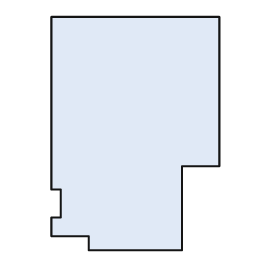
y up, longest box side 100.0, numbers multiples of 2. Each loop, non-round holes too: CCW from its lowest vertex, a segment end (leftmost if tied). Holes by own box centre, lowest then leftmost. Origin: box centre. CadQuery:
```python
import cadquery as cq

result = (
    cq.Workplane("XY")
    .moveTo(-20.0, -50.0)
    .lineTo(20.0, -50.0)
    .lineTo(20.0, -14.0)
    .lineTo(36.0, -14.0)
    .lineTo(36.0, 50.0)
    .lineTo(-36.0, 50.0)
    .lineTo(-36.0, -24.0)
    .lineTo(-32.0, -24.0)
    .lineTo(-32.0, -36.0)
    .lineTo(-36.0, -36.0)
    .lineTo(-36.0, -44.0)
    .lineTo(-20.0, -44.0)
    .close()
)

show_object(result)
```